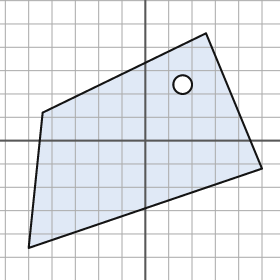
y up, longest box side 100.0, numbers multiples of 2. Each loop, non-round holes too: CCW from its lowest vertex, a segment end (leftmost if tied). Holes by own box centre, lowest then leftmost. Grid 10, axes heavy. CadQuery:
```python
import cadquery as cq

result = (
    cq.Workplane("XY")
    .moveTo(-50.0, -46.0)
    .lineTo(50.0, -12.0)
    .lineTo(26.0, 46.0)
    .lineTo(-44.0, 12.0)
    .close()
    .moveTo(16.0, 24.0)
    .circle(4.0)
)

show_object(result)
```